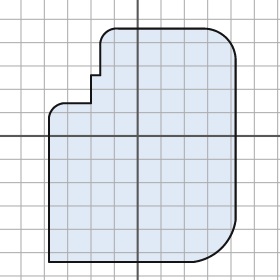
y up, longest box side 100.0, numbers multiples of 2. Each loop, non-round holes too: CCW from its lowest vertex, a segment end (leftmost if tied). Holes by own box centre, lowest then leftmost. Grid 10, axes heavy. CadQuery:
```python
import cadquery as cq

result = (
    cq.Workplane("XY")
    .moveTo(-38.0, -54.0)
    .lineTo(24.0, -54.0)
    .threePointArc((36.0, -48.0), (42.0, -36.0))
    .lineTo(42.0, 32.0)
    .threePointArc((38.0, 42.0), (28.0, 46.0))
    .lineTo(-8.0, 46.0)
    .threePointArc((-14.0, 44.0), (-16.0, 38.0))
    .lineTo(-16.0, 26.0)
    .lineTo(-20.0, 26.0)
    .lineTo(-20.0, 14.0)
    .lineTo(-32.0, 14.0)
    .threePointArc((-36.0, 12.0), (-38.0, 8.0))
    .close()
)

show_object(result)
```